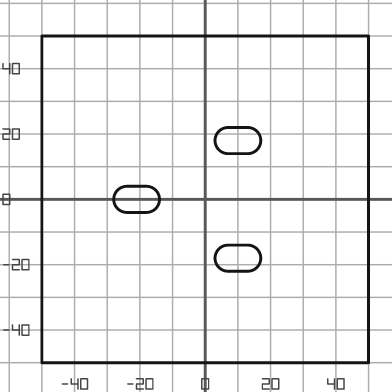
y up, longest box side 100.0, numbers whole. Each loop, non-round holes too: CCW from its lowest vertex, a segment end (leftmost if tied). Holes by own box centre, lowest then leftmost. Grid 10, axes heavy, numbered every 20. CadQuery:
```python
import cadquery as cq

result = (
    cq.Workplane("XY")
    .moveTo(-50.0, -50.0)
    .lineTo(50.0, -50.0)
    .lineTo(50.0, 50.0)
    .lineTo(-50.0, 50.0)
    .close()
    .moveTo(7.0, -22.0)
    .lineTo(13.0, -22.0)
    .threePointArc((17.0, -18.0), (13.0, -14.0))
    .lineTo(7.0, -14.0)
    .threePointArc((3.0, -18.0), (7.0, -22.0))
    .close()
    .moveTo(-24.0, -4.0)
    .lineTo(-18.0, -4.0)
    .threePointArc((-14.0, 0.0), (-18.0, 4.0))
    .lineTo(-24.0, 4.0)
    .threePointArc((-28.0, 0.0), (-24.0, -4.0))
    .close()
    .moveTo(7.0, 14.0)
    .lineTo(13.0, 14.0)
    .threePointArc((17.0, 18.0), (13.0, 22.0))
    .lineTo(7.0, 22.0)
    .threePointArc((3.0, 18.0), (7.0, 14.0))
    .close()
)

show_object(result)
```